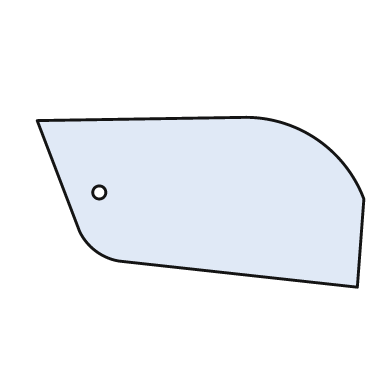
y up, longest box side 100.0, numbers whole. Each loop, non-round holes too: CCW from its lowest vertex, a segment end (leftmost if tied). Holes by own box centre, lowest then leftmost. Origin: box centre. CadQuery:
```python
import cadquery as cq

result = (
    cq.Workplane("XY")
    .moveTo(48.0, -26.0)
    .lineTo(50.0, 1.0)
    .threePointArc((36.0, 19.0), (14.0, 26.0))
    .lineTo(-50.0, 25.0)
    .lineTo(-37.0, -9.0)
    .threePointArc((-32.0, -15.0), (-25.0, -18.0))
    .close()
    .moveTo(-31.0, 3.0)
    .circle(2.0)
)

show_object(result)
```